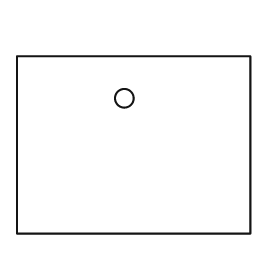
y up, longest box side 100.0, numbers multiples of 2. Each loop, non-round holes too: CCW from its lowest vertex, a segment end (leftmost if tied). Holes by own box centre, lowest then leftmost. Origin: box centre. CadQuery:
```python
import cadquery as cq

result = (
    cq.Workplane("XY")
    .moveTo(-50.0, -38.0)
    .lineTo(50.0, -38.0)
    .lineTo(50.0, 38.0)
    .lineTo(-50.0, 38.0)
    .close()
    .moveTo(-4.0, 20.0)
    .circle(4.0)
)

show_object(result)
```